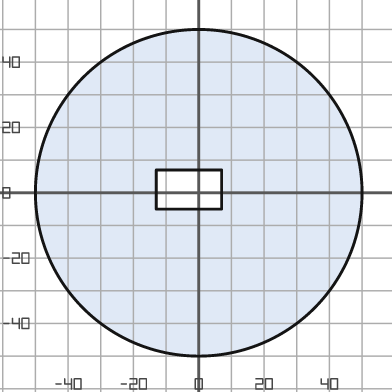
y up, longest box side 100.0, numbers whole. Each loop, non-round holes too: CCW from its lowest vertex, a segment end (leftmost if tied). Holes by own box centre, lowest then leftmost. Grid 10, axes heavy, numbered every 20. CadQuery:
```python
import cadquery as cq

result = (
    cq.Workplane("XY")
    .moveTo(0.0, 0.0)
    .circle(50.0)
    .moveTo(-13.0, -5.0)
    .lineTo(7.0, -5.0)
    .lineTo(7.0, 7.0)
    .lineTo(-13.0, 7.0)
    .close()
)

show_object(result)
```